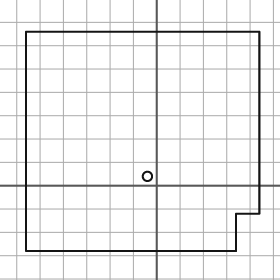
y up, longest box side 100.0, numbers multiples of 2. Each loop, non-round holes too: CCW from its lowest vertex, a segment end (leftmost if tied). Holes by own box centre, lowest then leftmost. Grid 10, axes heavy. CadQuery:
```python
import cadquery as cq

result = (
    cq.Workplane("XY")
    .moveTo(-56.0, -28.0)
    .lineTo(34.0, -28.0)
    .lineTo(34.0, -12.0)
    .lineTo(44.0, -12.0)
    .lineTo(44.0, 66.0)
    .lineTo(-56.0, 66.0)
    .close()
    .moveTo(-4.0, 4.0)
    .circle(2.0)
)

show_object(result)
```